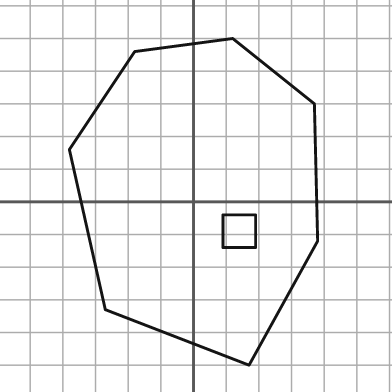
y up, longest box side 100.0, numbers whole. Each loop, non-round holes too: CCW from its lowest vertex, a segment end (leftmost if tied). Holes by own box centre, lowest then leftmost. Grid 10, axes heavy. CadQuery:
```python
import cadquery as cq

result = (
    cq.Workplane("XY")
    .moveTo(17.0, -50.0)
    .lineTo(38.0, -12.0)
    .lineTo(37.0, 30.0)
    .lineTo(12.0, 50.0)
    .lineTo(-18.0, 46.0)
    .lineTo(-38.0, 16.0)
    .lineTo(-27.0, -33.0)
    .close()
    .moveTo(9.0, -14.0)
    .lineTo(19.0, -14.0)
    .lineTo(19.0, -4.0)
    .lineTo(9.0, -4.0)
    .close()
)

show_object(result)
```